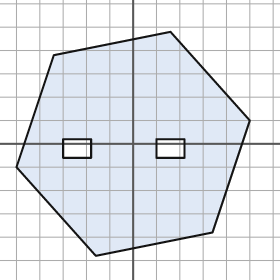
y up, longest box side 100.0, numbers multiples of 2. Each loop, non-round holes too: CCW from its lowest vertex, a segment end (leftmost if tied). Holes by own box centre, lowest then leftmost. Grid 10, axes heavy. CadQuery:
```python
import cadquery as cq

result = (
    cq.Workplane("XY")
    .moveTo(-16.0, -48.0)
    .lineTo(34.0, -38.0)
    .lineTo(50.0, 10.0)
    .lineTo(16.0, 48.0)
    .lineTo(-34.0, 38.0)
    .lineTo(-50.0, -10.0)
    .close()
    .moveTo(-30.0, -6.0)
    .lineTo(-18.0, -6.0)
    .lineTo(-18.0, 2.0)
    .lineTo(-30.0, 2.0)
    .close()
    .moveTo(10.0, -6.0)
    .lineTo(22.0, -6.0)
    .lineTo(22.0, 2.0)
    .lineTo(10.0, 2.0)
    .close()
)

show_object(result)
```